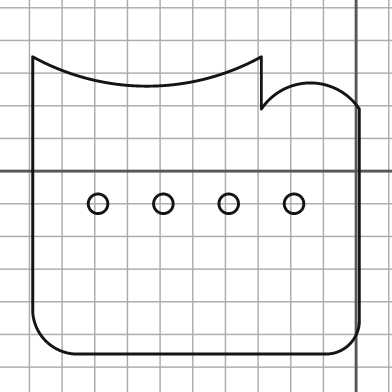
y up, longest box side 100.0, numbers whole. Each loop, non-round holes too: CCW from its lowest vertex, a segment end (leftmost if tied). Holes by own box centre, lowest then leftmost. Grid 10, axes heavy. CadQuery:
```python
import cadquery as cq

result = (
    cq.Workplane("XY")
    .moveTo(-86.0, -56.0)
    .lineTo(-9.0, -56.0)
    .threePointArc((-2.0, -53.0), (1.0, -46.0))
    .lineTo(1.0, 19.0)
    .threePointArc((-14.0, 27.0), (-29.0, 19.0))
    .lineTo(-29.0, 35.0)
    .threePointArc((-64.0, 26.0), (-99.0, 35.0))
    .lineTo(-99.0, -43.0)
    .threePointArc((-95.0, -52.0), (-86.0, -56.0))
    .close()
    .moveTo(-79.0, -10.0)
    .circle(3.0)
    .moveTo(-59.0, -10.0)
    .circle(3.0)
    .moveTo(-39.0, -10.0)
    .circle(3.0)
    .moveTo(-19.0, -10.0)
    .circle(3.0)
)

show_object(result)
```